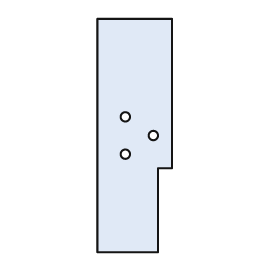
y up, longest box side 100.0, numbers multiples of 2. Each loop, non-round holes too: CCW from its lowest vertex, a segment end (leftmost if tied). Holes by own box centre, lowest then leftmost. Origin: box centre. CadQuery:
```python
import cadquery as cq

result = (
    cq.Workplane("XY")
    .moveTo(-16.0, -50.0)
    .lineTo(10.0, -50.0)
    .lineTo(10.0, -14.0)
    .lineTo(16.0, -14.0)
    .lineTo(16.0, 50.0)
    .lineTo(-16.0, 50.0)
    .close()
    .moveTo(-4.0, -8.0)
    .circle(2.0)
    .moveTo(8.0, 0.0)
    .circle(2.0)
    .moveTo(-4.0, 8.0)
    .circle(2.0)
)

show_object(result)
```